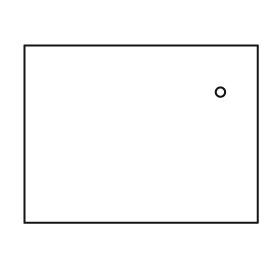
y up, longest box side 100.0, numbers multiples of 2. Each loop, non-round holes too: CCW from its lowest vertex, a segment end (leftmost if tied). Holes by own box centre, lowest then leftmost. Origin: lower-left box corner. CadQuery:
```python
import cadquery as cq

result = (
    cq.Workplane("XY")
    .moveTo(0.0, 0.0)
    .lineTo(100.0, 0.0)
    .lineTo(100.0, 76.0)
    .lineTo(0.0, 76.0)
    .close()
    .moveTo(84.0, 56.0)
    .circle(2.0)
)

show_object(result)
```